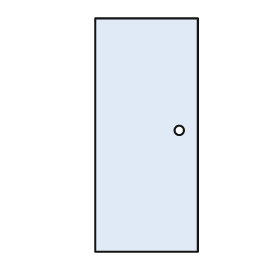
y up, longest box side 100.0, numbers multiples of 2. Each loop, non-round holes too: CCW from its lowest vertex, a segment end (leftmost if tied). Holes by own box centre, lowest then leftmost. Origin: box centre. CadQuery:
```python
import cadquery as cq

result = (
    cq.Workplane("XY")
    .moveTo(-22.0, -50.0)
    .lineTo(22.0, -50.0)
    .lineTo(22.0, 50.0)
    .lineTo(-22.0, 50.0)
    .close()
    .moveTo(14.0, 2.0)
    .circle(2.0)
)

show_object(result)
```